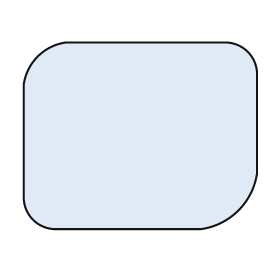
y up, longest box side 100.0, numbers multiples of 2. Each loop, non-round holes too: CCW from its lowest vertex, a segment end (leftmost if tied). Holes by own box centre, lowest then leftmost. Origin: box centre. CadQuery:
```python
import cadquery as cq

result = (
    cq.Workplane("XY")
    .moveTo(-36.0, -40.0)
    .lineTo(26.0, -40.0)
    .threePointArc((42.0, -32.0), (50.0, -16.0))
    .lineTo(50.0, 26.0)
    .threePointArc((46.0, 36.0), (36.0, 40.0))
    .lineTo(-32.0, 40.0)
    .threePointArc((-44.0, 34.0), (-50.0, 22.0))
    .lineTo(-50.0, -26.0)
    .threePointArc((-46.0, -36.0), (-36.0, -40.0))
    .close()
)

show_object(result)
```